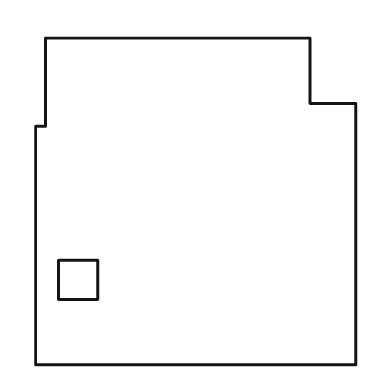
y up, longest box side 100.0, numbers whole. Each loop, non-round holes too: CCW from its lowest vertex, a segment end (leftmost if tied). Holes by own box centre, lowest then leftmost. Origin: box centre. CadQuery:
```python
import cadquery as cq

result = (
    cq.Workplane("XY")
    .moveTo(-49.0, -50.0)
    .lineTo(49.0, -50.0)
    .lineTo(49.0, 30.0)
    .lineTo(35.0, 30.0)
    .lineTo(35.0, 50.0)
    .lineTo(-46.0, 50.0)
    .lineTo(-46.0, 23.0)
    .lineTo(-49.0, 23.0)
    .close()
    .moveTo(-42.0, -30.0)
    .lineTo(-30.0, -30.0)
    .lineTo(-30.0, -18.0)
    .lineTo(-42.0, -18.0)
    .close()
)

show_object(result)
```